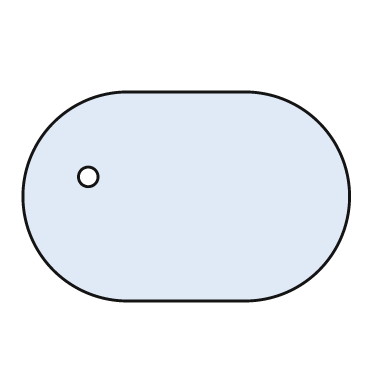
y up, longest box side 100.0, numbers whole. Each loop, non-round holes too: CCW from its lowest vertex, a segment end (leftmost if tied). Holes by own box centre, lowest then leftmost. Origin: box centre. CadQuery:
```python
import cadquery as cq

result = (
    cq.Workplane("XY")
    .moveTo(-18.0, -32.0)
    .lineTo(18.0, -32.0)
    .threePointArc((50.0, 0.0), (18.0, 32.0))
    .lineTo(-18.0, 32.0)
    .threePointArc((-50.0, 0.0), (-18.0, -32.0))
    .close()
    .moveTo(-30.0, 6.0)
    .circle(3.0)
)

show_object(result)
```